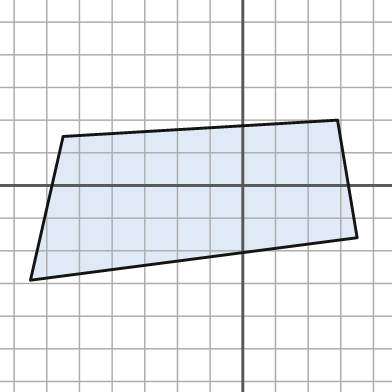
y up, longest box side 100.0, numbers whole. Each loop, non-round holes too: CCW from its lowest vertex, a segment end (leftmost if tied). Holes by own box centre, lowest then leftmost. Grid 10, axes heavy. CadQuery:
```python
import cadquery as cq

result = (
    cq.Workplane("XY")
    .moveTo(-65.0, -29.0)
    .lineTo(35.0, -16.0)
    .lineTo(29.0, 20.0)
    .lineTo(-55.0, 15.0)
    .close()
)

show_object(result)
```